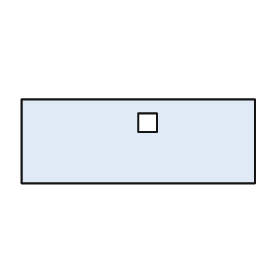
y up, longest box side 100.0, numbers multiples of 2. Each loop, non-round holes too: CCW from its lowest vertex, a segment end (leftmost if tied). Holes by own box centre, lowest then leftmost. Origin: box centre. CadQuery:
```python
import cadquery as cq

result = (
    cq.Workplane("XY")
    .moveTo(-50.0, -18.0)
    .lineTo(50.0, -18.0)
    .lineTo(50.0, 18.0)
    .lineTo(-50.0, 18.0)
    .close()
    .moveTo(0.0, 4.0)
    .lineTo(8.0, 4.0)
    .lineTo(8.0, 12.0)
    .lineTo(0.0, 12.0)
    .close()
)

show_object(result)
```